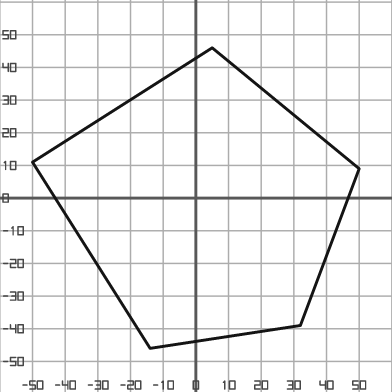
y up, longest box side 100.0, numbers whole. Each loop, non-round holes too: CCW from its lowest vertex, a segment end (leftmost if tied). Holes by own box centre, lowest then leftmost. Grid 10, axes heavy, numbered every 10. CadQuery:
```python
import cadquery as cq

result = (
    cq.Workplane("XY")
    .moveTo(-14.0, -46.0)
    .lineTo(32.0, -39.0)
    .lineTo(50.0, 9.0)
    .lineTo(5.0, 46.0)
    .lineTo(-50.0, 11.0)
    .close()
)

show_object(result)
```